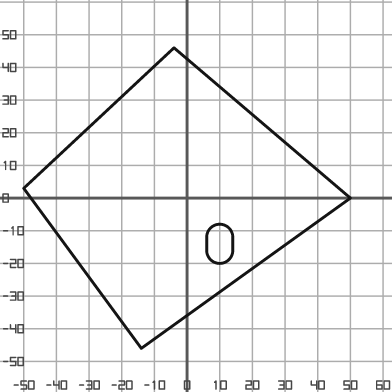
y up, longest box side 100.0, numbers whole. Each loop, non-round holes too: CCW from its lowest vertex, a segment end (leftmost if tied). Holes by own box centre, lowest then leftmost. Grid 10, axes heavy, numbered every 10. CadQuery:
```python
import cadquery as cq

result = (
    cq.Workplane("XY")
    .moveTo(-14.0, -46.0)
    .lineTo(50.0, 0.0)
    .lineTo(-4.0, 46.0)
    .lineTo(-50.0, 3.0)
    .close()
    .moveTo(6.0, -16.0)
    .threePointArc((10.0, -20.0), (14.0, -16.0))
    .lineTo(14.0, -12.0)
    .threePointArc((10.0, -8.0), (6.0, -12.0))
    .close()
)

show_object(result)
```